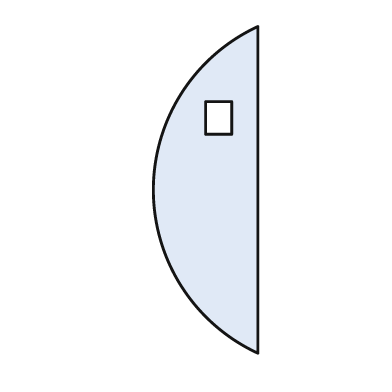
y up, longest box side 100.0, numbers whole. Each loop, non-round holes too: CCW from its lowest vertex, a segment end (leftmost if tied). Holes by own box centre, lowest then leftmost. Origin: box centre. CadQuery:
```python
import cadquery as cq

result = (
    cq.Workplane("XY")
    .moveTo(16.0, -50.0)
    .lineTo(16.0, 50.0)
    .threePointArc((-16.0, 0.0), (16.0, -50.0))
    .close()
    .moveTo(0.0, 17.0)
    .lineTo(8.0, 17.0)
    .lineTo(8.0, 27.0)
    .lineTo(0.0, 27.0)
    .close()
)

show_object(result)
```